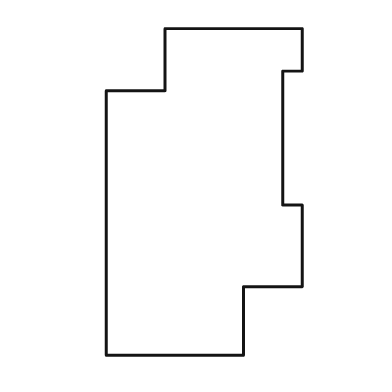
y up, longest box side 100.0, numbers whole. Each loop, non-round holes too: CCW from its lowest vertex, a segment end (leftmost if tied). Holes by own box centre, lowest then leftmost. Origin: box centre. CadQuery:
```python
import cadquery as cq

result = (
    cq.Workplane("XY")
    .moveTo(-30.0, -50.0)
    .lineTo(12.0, -50.0)
    .lineTo(12.0, -29.0)
    .lineTo(30.0, -29.0)
    .lineTo(30.0, -4.0)
    .lineTo(24.0, -4.0)
    .lineTo(24.0, 37.0)
    .lineTo(30.0, 37.0)
    .lineTo(30.0, 50.0)
    .lineTo(-12.0, 50.0)
    .lineTo(-12.0, 31.0)
    .lineTo(-30.0, 31.0)
    .close()
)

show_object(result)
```